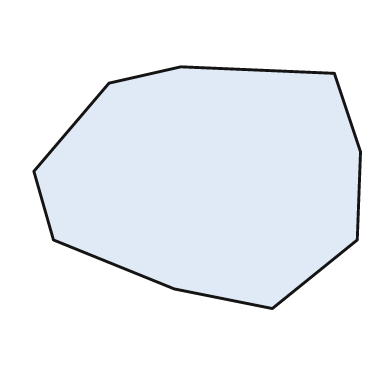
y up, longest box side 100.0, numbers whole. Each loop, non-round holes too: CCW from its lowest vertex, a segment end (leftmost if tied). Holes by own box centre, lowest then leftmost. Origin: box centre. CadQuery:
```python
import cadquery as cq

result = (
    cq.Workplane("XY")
    .moveTo(23.0, -37.0)
    .lineTo(49.0, -16.0)
    .lineTo(50.0, 11.0)
    .lineTo(42.0, 35.0)
    .lineTo(-5.0, 37.0)
    .lineTo(-27.0, 32.0)
    .lineTo(-50.0, 5.0)
    .lineTo(-44.0, -16.0)
    .lineTo(-7.0, -31.0)
    .close()
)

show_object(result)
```